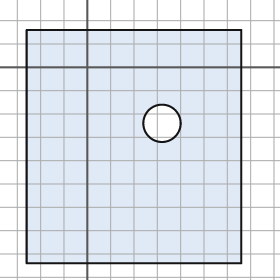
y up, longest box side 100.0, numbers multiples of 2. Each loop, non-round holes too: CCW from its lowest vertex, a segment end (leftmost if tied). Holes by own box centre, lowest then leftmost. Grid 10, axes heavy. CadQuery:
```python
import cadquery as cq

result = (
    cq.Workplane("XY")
    .moveTo(-26.0, -84.0)
    .lineTo(66.0, -84.0)
    .lineTo(66.0, 16.0)
    .lineTo(-26.0, 16.0)
    .close()
    .moveTo(32.0, -24.0)
    .circle(8.0)
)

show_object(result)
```